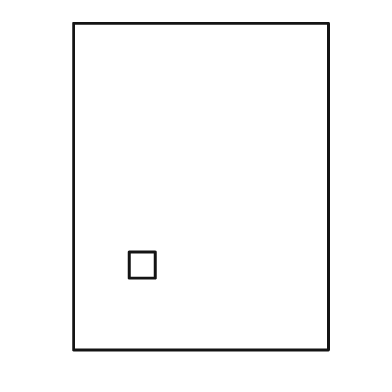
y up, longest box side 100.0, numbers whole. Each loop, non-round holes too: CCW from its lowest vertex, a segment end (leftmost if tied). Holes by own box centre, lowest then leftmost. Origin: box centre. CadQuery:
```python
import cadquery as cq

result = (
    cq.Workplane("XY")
    .moveTo(-39.0, -50.0)
    .lineTo(39.0, -50.0)
    .lineTo(39.0, 50.0)
    .lineTo(-39.0, 50.0)
    .close()
    .moveTo(-22.0, -28.0)
    .lineTo(-14.0, -28.0)
    .lineTo(-14.0, -20.0)
    .lineTo(-22.0, -20.0)
    .close()
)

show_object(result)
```